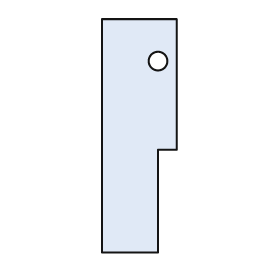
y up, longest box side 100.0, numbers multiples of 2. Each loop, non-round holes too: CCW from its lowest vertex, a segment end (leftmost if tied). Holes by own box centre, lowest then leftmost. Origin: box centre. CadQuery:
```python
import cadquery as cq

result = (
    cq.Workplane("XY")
    .moveTo(-16.0, -50.0)
    .lineTo(8.0, -50.0)
    .lineTo(8.0, -6.0)
    .lineTo(16.0, -6.0)
    .lineTo(16.0, 50.0)
    .lineTo(-16.0, 50.0)
    .close()
    .moveTo(8.0, 32.0)
    .circle(4.0)
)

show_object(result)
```